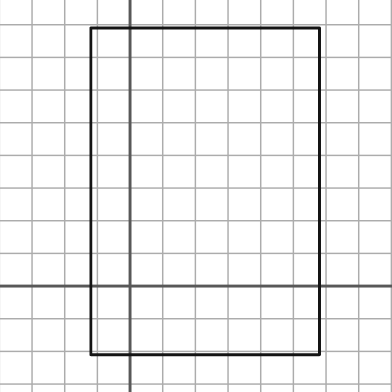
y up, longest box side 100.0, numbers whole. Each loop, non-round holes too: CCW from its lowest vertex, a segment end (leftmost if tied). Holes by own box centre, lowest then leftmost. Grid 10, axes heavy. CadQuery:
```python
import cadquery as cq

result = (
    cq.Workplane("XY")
    .moveTo(-12.0, -21.0)
    .lineTo(58.0, -21.0)
    .lineTo(58.0, 79.0)
    .lineTo(-12.0, 79.0)
    .close()
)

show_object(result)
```